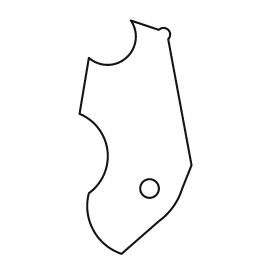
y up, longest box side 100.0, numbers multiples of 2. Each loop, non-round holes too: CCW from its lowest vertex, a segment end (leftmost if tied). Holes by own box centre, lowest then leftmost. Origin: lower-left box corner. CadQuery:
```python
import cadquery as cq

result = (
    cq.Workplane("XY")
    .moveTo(18.0, 0.0)
    .lineTo(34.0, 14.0)
    .threePointArc((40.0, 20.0), (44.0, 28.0))
    .lineTo(48.0, 38.0)
    .lineTo(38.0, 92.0)
    .threePointArc((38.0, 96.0), (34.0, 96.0))
    .lineTo(22.0, 100.0)
    .threePointArc((20.0, 84.0), (4.0, 84.0))
    .lineTo(0.0, 60.0)
    .threePointArc((12.0, 44.0), (4.0, 26.0))
    .threePointArc((6.0, 10.0), (18.0, 0.0))
    .close()
    .moveTo(30.0, 28.0)
    .circle(4.0)
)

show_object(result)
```